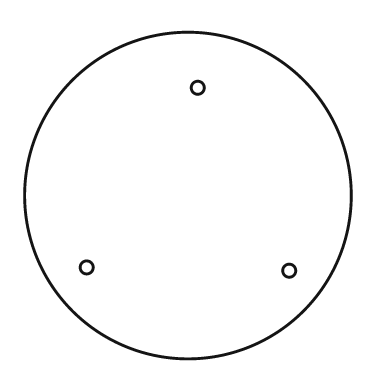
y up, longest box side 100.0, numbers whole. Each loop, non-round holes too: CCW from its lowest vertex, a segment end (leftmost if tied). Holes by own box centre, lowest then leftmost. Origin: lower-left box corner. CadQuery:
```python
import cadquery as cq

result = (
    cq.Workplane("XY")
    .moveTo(50.0, 50.0)
    .circle(50.0)
    .moveTo(81.0, 27.0)
    .circle(2.0)
    .moveTo(19.0, 28.0)
    .circle(2.0)
    .moveTo(53.0, 83.0)
    .circle(2.0)
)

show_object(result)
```